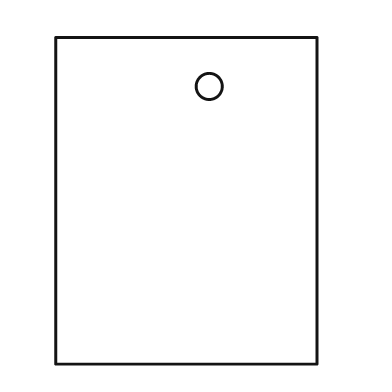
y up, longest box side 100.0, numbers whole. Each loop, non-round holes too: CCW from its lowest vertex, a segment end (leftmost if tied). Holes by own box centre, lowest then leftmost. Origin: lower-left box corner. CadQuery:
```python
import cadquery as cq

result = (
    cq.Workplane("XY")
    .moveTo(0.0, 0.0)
    .lineTo(80.0, 0.0)
    .lineTo(80.0, 100.0)
    .lineTo(0.0, 100.0)
    .close()
    .moveTo(47.0, 85.0)
    .circle(4.0)
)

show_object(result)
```